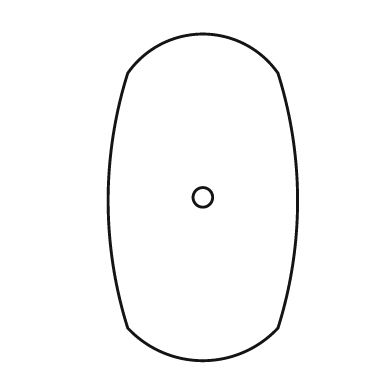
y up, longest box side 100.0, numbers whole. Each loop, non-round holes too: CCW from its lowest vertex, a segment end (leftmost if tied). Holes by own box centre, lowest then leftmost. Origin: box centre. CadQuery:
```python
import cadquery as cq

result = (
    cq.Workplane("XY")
    .moveTo(-23.0, -40.0)
    .threePointArc((0.0, -50.0), (23.0, -40.0))
    .threePointArc((29.0, -1.0), (23.0, 38.0))
    .threePointArc((0.0, 50.0), (-23.0, 38.0))
    .threePointArc((-29.0, -1.0), (-23.0, -40.0))
    .close()
    .moveTo(0.0, 0.0)
    .circle(3.0)
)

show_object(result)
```